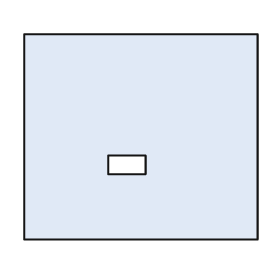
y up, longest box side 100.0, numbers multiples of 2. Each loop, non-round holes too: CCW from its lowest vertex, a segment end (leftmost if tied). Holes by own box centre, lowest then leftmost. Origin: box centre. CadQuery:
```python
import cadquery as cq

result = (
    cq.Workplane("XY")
    .moveTo(-50.0, -44.0)
    .lineTo(50.0, -44.0)
    .lineTo(50.0, 44.0)
    .lineTo(-50.0, 44.0)
    .close()
    .moveTo(-14.0, -16.0)
    .lineTo(2.0, -16.0)
    .lineTo(2.0, -8.0)
    .lineTo(-14.0, -8.0)
    .close()
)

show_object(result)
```